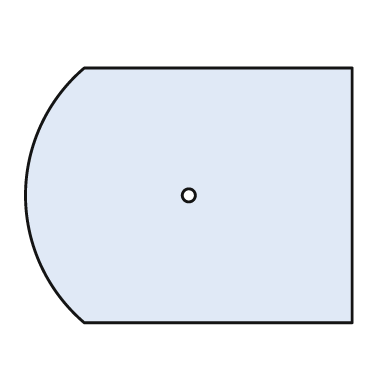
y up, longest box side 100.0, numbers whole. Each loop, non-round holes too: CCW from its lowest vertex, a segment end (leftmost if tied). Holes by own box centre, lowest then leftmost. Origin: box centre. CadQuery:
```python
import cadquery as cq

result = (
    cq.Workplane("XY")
    .moveTo(-32.0, -39.0)
    .lineTo(50.0, -39.0)
    .lineTo(50.0, 39.0)
    .lineTo(-32.0, 39.0)
    .threePointArc((-50.0, 0.0), (-32.0, -39.0))
    .close()
    .moveTo(0.0, 0.0)
    .circle(2.0)
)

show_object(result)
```